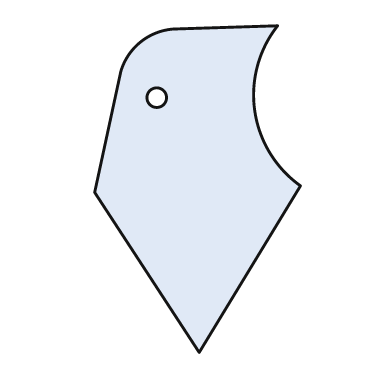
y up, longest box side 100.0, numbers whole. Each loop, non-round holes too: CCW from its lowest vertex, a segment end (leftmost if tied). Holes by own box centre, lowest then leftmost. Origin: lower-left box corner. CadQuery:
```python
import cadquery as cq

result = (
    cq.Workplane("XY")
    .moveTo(32.0, 0.0)
    .lineTo(63.0, 51.0)
    .threePointArc((49.0, 74.0), (56.0, 100.0))
    .lineTo(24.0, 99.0)
    .threePointArc((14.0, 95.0), (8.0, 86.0))
    .lineTo(0.0, 49.0)
    .close()
    .moveTo(19.0, 78.0)
    .circle(3.0)
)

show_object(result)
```